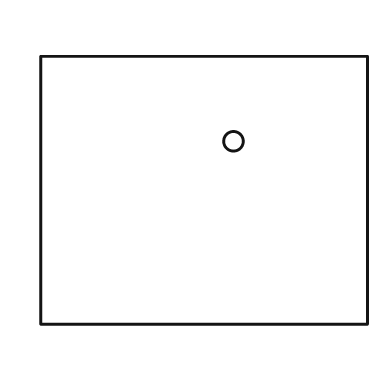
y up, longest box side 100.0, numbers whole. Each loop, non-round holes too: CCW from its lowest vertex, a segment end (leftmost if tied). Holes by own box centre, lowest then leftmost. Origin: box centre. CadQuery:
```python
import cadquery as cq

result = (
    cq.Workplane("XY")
    .moveTo(-50.0, -41.0)
    .lineTo(50.0, -41.0)
    .lineTo(50.0, 41.0)
    .lineTo(-50.0, 41.0)
    .close()
    .moveTo(9.0, 15.0)
    .circle(3.0)
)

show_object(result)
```